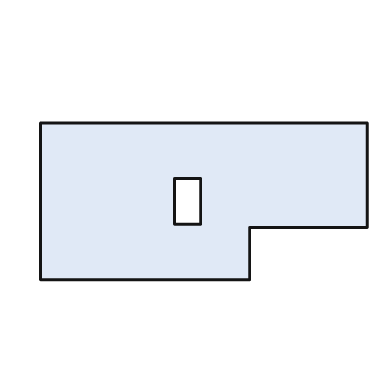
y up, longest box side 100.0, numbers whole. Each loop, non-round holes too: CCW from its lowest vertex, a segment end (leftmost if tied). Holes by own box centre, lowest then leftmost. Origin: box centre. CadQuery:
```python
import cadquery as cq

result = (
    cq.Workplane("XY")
    .moveTo(-50.0, -24.0)
    .lineTo(14.0, -24.0)
    .lineTo(14.0, -8.0)
    .lineTo(50.0, -8.0)
    .lineTo(50.0, 24.0)
    .lineTo(-50.0, 24.0)
    .close()
    .moveTo(-9.0, -7.0)
    .lineTo(-1.0, -7.0)
    .lineTo(-1.0, 7.0)
    .lineTo(-9.0, 7.0)
    .close()
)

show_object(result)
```